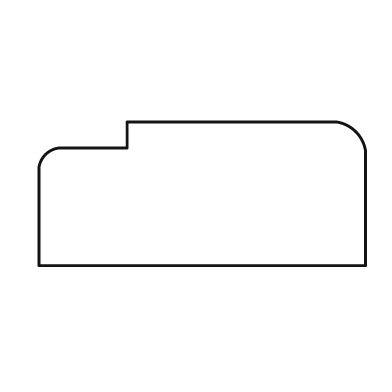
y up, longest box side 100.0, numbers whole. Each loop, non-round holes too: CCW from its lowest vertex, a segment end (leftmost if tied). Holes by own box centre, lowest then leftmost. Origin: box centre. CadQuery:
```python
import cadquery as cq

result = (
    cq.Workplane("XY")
    .moveTo(-50.0, -22.0)
    .lineTo(50.0, -22.0)
    .lineTo(50.0, 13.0)
    .threePointArc((47.0, 19.0), (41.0, 22.0))
    .lineTo(-23.0, 22.0)
    .lineTo(-23.0, 14.0)
    .lineTo(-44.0, 14.0)
    .threePointArc((-48.0, 12.0), (-50.0, 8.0))
    .close()
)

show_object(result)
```